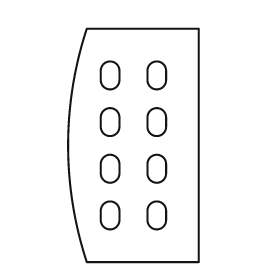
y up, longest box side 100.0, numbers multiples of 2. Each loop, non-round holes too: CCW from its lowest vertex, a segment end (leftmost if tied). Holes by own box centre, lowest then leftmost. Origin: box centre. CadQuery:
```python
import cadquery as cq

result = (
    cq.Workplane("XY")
    .moveTo(-20.0, -50.0)
    .lineTo(28.0, -50.0)
    .lineTo(28.0, 50.0)
    .lineTo(-20.0, 50.0)
    .threePointArc((-28.0, 0.0), (-20.0, -50.0))
    .close()
    .moveTo(-14.0, -32.0)
    .threePointArc((-10.0, -36.0), (-6.0, -32.0))
    .lineTo(-6.0, -28.0)
    .threePointArc((-10.0, -24.0), (-14.0, -28.0))
    .close()
    .moveTo(6.0, -32.0)
    .threePointArc((10.0, -36.0), (14.0, -32.0))
    .lineTo(14.0, -28.0)
    .threePointArc((10.0, -24.0), (6.0, -28.0))
    .close()
    .moveTo(-14.0, -12.0)
    .threePointArc((-10.0, -16.0), (-6.0, -12.0))
    .lineTo(-6.0, -8.0)
    .threePointArc((-10.0, -4.0), (-14.0, -8.0))
    .close()
    .moveTo(6.0, -12.0)
    .threePointArc((10.0, -16.0), (14.0, -12.0))
    .lineTo(14.0, -8.0)
    .threePointArc((10.0, -4.0), (6.0, -8.0))
    .close()
    .moveTo(-14.0, 8.0)
    .threePointArc((-10.0, 4.0), (-6.0, 8.0))
    .lineTo(-6.0, 12.0)
    .threePointArc((-10.0, 16.0), (-14.0, 12.0))
    .close()
    .moveTo(6.0, 8.0)
    .threePointArc((10.0, 4.0), (14.0, 8.0))
    .lineTo(14.0, 12.0)
    .threePointArc((10.0, 16.0), (6.0, 12.0))
    .close()
    .moveTo(-14.0, 28.0)
    .threePointArc((-10.0, 24.0), (-6.0, 28.0))
    .lineTo(-6.0, 32.0)
    .threePointArc((-10.0, 36.0), (-14.0, 32.0))
    .close()
    .moveTo(6.0, 28.0)
    .threePointArc((10.0, 24.0), (14.0, 28.0))
    .lineTo(14.0, 32.0)
    .threePointArc((10.0, 36.0), (6.0, 32.0))
    .close()
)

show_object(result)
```